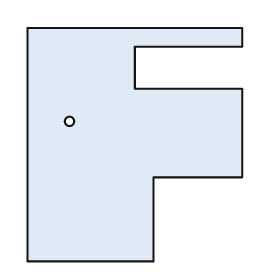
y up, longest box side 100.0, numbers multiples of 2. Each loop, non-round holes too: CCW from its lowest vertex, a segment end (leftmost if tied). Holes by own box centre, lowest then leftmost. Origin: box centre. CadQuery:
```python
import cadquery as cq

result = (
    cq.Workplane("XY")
    .moveTo(-46.0, -50.0)
    .lineTo(8.0, -50.0)
    .lineTo(8.0, -14.0)
    .lineTo(46.0, -14.0)
    .lineTo(46.0, 24.0)
    .lineTo(0.0, 24.0)
    .lineTo(0.0, 42.0)
    .lineTo(46.0, 42.0)
    .lineTo(46.0, 50.0)
    .lineTo(-46.0, 50.0)
    .close()
    .moveTo(-28.0, 10.0)
    .circle(2.0)
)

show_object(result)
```